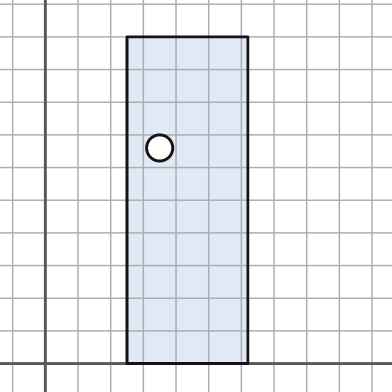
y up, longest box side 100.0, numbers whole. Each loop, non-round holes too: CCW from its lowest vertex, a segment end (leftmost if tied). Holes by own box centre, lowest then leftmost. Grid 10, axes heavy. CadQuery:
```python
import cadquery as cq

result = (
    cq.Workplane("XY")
    .moveTo(25.0, 0.0)
    .lineTo(62.0, 0.0)
    .lineTo(62.0, 100.0)
    .lineTo(25.0, 100.0)
    .close()
    .moveTo(35.0, 66.0)
    .circle(4.0)
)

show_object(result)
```